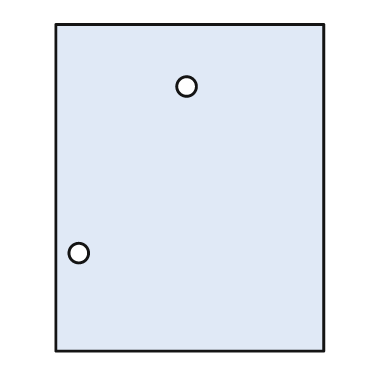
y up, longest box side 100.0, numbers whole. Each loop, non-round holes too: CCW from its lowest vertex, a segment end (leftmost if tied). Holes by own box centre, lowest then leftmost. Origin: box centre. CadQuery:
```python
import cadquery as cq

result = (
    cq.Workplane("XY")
    .moveTo(-41.0, -50.0)
    .lineTo(41.0, -50.0)
    .lineTo(41.0, 50.0)
    .lineTo(-41.0, 50.0)
    .close()
    .moveTo(-34.0, -20.0)
    .circle(3.0)
    .moveTo(-1.0, 31.0)
    .circle(3.0)
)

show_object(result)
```